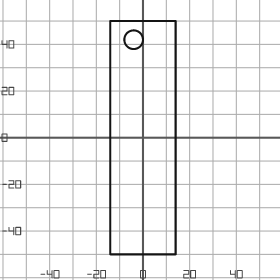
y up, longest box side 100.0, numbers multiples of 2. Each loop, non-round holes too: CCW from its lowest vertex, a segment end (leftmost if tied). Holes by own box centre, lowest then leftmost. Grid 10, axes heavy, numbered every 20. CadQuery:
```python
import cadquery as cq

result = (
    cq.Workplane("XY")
    .moveTo(-14.0, -50.0)
    .lineTo(14.0, -50.0)
    .lineTo(14.0, 50.0)
    .lineTo(-14.0, 50.0)
    .close()
    .moveTo(-4.0, 42.0)
    .circle(4.0)
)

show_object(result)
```